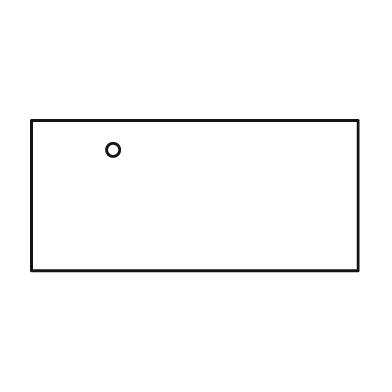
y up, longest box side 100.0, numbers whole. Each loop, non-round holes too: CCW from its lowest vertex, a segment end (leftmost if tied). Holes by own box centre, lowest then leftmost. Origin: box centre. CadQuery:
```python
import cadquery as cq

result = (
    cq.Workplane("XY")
    .moveTo(-50.0, -23.0)
    .lineTo(50.0, -23.0)
    .lineTo(50.0, 23.0)
    .lineTo(-50.0, 23.0)
    .close()
    .moveTo(-25.0, 14.0)
    .circle(2.0)
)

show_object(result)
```